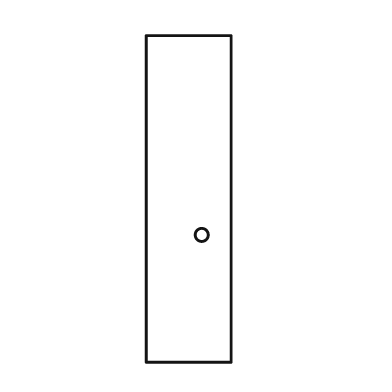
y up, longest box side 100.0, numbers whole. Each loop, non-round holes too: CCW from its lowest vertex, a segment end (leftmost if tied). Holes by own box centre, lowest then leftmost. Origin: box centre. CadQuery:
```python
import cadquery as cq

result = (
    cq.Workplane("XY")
    .moveTo(-13.0, -50.0)
    .lineTo(13.0, -50.0)
    .lineTo(13.0, 50.0)
    .lineTo(-13.0, 50.0)
    .close()
    .moveTo(4.0, -11.0)
    .circle(2.0)
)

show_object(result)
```